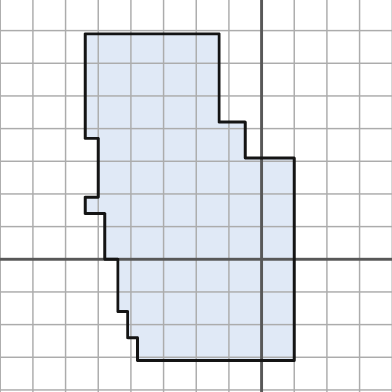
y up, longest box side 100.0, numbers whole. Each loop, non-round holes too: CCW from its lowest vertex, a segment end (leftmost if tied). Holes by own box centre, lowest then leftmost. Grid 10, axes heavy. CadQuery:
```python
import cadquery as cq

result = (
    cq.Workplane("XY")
    .moveTo(-38.0, -31.0)
    .lineTo(10.0, -31.0)
    .lineTo(10.0, 31.0)
    .lineTo(-5.0, 31.0)
    .lineTo(-5.0, 42.0)
    .lineTo(-13.0, 42.0)
    .lineTo(-13.0, 69.0)
    .lineTo(-54.0, 69.0)
    .lineTo(-54.0, 37.0)
    .lineTo(-50.0, 37.0)
    .lineTo(-50.0, 19.0)
    .lineTo(-54.0, 19.0)
    .lineTo(-54.0, 14.0)
    .lineTo(-48.0, 14.0)
    .lineTo(-48.0, 0.0)
    .lineTo(-44.0, 0.0)
    .lineTo(-44.0, -16.0)
    .lineTo(-41.0, -16.0)
    .lineTo(-41.0, -24.0)
    .lineTo(-38.0, -24.0)
    .close()
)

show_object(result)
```